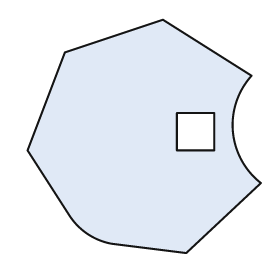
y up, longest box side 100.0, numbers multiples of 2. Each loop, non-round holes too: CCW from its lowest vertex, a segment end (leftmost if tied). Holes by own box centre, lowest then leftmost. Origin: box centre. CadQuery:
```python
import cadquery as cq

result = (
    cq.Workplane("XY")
    .moveTo(18.0, -50.0)
    .lineTo(50.0, -20.0)
    .threePointArc((38.0, 2.0), (46.0, 26.0))
    .lineTo(8.0, 50.0)
    .lineTo(-34.0, 36.0)
    .lineTo(-50.0, -6.0)
    .lineTo(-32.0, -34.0)
    .threePointArc((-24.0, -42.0), (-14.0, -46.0))
    .close()
    .moveTo(14.0, -6.0)
    .lineTo(30.0, -6.0)
    .lineTo(30.0, 10.0)
    .lineTo(14.0, 10.0)
    .close()
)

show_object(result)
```